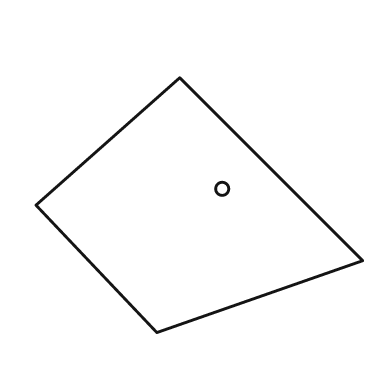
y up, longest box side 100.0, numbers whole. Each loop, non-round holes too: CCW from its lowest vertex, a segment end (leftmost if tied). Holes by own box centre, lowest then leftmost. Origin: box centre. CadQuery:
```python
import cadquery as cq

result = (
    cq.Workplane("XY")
    .moveTo(-13.0, -39.0)
    .lineTo(50.0, -17.0)
    .lineTo(-6.0, 39.0)
    .lineTo(-50.0, 0.0)
    .close()
    .moveTo(7.0, 5.0)
    .circle(2.0)
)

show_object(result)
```